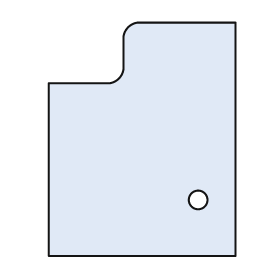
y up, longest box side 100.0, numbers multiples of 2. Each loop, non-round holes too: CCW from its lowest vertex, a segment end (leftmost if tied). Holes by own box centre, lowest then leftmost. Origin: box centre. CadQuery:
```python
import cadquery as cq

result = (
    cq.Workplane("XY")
    .moveTo(-40.0, -50.0)
    .lineTo(40.0, -50.0)
    .lineTo(40.0, 50.0)
    .lineTo(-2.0, 50.0)
    .threePointArc((-6.0, 48.0), (-8.0, 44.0))
    .lineTo(-8.0, 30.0)
    .threePointArc((-10.0, 26.0), (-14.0, 24.0))
    .lineTo(-40.0, 24.0)
    .close()
    .moveTo(24.0, -26.0)
    .circle(4.0)
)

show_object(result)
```